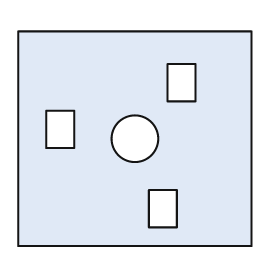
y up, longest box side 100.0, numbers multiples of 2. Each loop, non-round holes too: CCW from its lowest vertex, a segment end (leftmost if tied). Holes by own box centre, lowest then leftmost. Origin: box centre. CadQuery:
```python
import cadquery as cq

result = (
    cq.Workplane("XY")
    .moveTo(-50.0, -46.0)
    .lineTo(50.0, -46.0)
    .lineTo(50.0, 46.0)
    .lineTo(-50.0, 46.0)
    .close()
    .moveTo(6.0, -38.0)
    .lineTo(18.0, -38.0)
    .lineTo(18.0, -22.0)
    .lineTo(6.0, -22.0)
    .close()
    .moveTo(0.0, 0.0)
    .circle(10.0)
    .moveTo(-38.0, -4.0)
    .lineTo(-26.0, -4.0)
    .lineTo(-26.0, 12.0)
    .lineTo(-38.0, 12.0)
    .close()
    .moveTo(14.0, 16.0)
    .lineTo(26.0, 16.0)
    .lineTo(26.0, 32.0)
    .lineTo(14.0, 32.0)
    .close()
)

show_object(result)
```